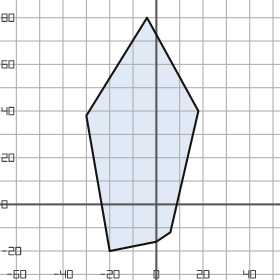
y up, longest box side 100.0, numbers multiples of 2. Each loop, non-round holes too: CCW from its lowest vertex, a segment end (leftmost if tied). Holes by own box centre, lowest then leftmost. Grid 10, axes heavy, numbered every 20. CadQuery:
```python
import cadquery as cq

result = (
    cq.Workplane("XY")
    .moveTo(-20.0, -20.0)
    .lineTo(0.0, -16.0)
    .lineTo(6.0, -12.0)
    .lineTo(18.0, 40.0)
    .lineTo(-4.0, 80.0)
    .lineTo(-30.0, 38.0)
    .close()
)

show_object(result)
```